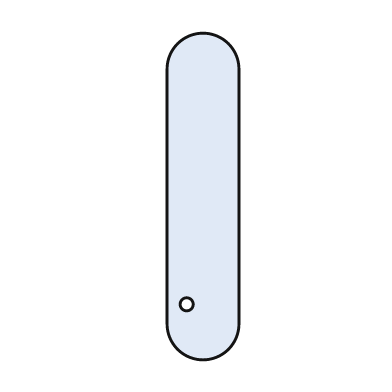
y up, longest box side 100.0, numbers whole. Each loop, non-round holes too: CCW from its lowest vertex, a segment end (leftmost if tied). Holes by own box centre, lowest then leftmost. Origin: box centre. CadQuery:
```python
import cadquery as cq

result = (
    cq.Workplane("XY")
    .moveTo(-11.0, -39.0)
    .threePointArc((0.0, -50.0), (11.0, -39.0))
    .lineTo(11.0, 39.0)
    .threePointArc((0.0, 50.0), (-11.0, 39.0))
    .close()
    .moveTo(-5.0, -33.0)
    .circle(2.0)
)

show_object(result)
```